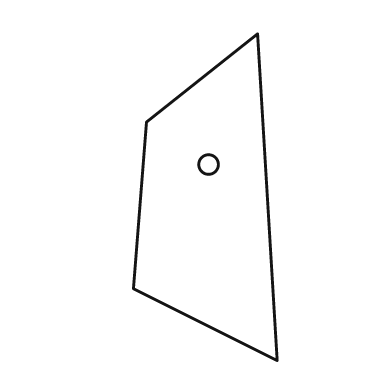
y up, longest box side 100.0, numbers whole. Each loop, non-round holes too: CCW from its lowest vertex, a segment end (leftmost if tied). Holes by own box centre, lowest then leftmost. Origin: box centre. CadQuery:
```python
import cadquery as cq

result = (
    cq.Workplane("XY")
    .moveTo(22.0, -50.0)
    .lineTo(16.0, 50.0)
    .lineTo(-18.0, 23.0)
    .lineTo(-22.0, -28.0)
    .close()
    .moveTo(1.0, 10.0)
    .circle(3.0)
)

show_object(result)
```